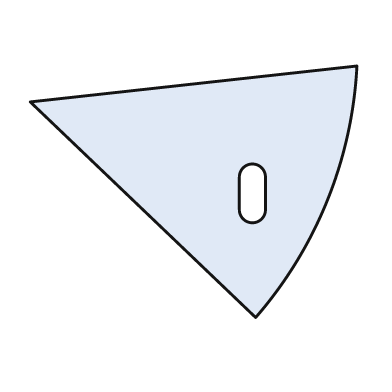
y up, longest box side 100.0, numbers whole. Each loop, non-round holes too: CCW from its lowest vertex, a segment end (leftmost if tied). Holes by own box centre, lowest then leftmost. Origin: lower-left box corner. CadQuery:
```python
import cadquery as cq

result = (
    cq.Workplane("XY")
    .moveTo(69.0, 0.0)
    .threePointArc((91.0, 36.0), (100.0, 77.0))
    .lineTo(0.0, 66.0)
    .close()
    .moveTo(64.0, 33.0)
    .threePointArc((68.0, 29.0), (72.0, 33.0))
    .lineTo(72.0, 43.0)
    .threePointArc((68.0, 47.0), (64.0, 43.0))
    .close()
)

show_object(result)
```